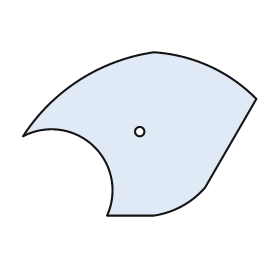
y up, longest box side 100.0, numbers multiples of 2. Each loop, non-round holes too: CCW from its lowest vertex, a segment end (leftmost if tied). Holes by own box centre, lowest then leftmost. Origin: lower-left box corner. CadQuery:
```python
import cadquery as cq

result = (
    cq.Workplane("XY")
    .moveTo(36.0, 0.0)
    .lineTo(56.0, 0.0)
    .threePointArc((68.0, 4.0), (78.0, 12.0))
    .lineTo(100.0, 50.0)
    .threePointArc((80.0, 64.0), (56.0, 70.0))
    .threePointArc((24.0, 58.0), (0.0, 34.0))
    .threePointArc((30.0, 30.0), (36.0, 0.0))
    .close()
    .moveTo(50.0, 36.0)
    .circle(2.0)
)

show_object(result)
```